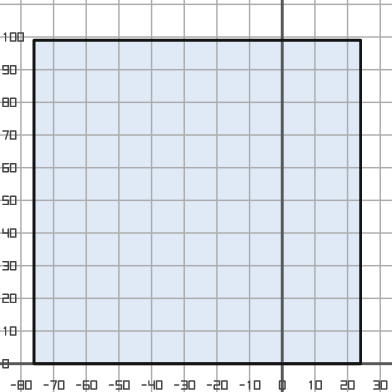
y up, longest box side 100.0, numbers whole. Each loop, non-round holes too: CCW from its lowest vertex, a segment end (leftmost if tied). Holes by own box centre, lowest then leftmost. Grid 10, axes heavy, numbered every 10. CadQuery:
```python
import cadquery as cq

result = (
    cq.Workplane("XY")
    .moveTo(-76.0, 0.0)
    .lineTo(24.0, 0.0)
    .lineTo(24.0, 99.0)
    .lineTo(-76.0, 99.0)
    .close()
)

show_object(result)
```